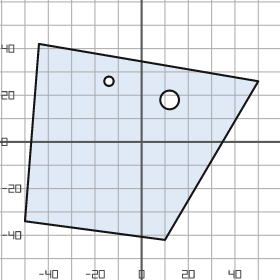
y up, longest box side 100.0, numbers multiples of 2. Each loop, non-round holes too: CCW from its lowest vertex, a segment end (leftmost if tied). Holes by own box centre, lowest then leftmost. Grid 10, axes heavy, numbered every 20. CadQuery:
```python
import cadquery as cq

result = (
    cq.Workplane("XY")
    .moveTo(10.0, -42.0)
    .lineTo(50.0, 26.0)
    .lineTo(-44.0, 42.0)
    .lineTo(-50.0, -34.0)
    .close()
    .moveTo(12.0, 18.0)
    .circle(4.0)
    .moveTo(-14.0, 26.0)
    .circle(2.0)
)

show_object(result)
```